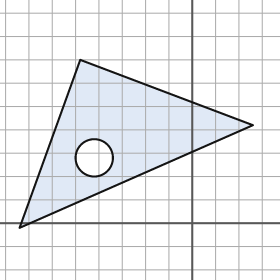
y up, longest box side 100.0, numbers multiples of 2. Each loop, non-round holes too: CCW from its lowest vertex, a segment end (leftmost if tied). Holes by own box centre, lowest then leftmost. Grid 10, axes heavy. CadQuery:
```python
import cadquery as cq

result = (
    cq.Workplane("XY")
    .moveTo(-74.0, -2.0)
    .lineTo(26.0, 42.0)
    .lineTo(-48.0, 70.0)
    .close()
    .moveTo(-42.0, 28.0)
    .circle(8.0)
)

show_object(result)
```